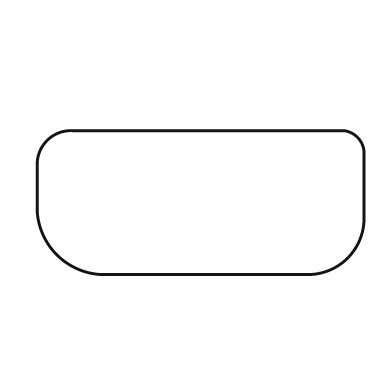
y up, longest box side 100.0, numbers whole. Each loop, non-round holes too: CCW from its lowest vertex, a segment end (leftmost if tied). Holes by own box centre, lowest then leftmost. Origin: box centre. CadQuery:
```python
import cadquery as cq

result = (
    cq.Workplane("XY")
    .moveTo(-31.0, -22.0)
    .lineTo(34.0, -22.0)
    .threePointArc((45.0, -17.0), (50.0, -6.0))
    .lineTo(50.0, 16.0)
    .threePointArc((48.0, 20.0), (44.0, 22.0))
    .lineTo(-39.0, 22.0)
    .threePointArc((-47.0, 19.0), (-50.0, 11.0))
    .lineTo(-50.0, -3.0)
    .threePointArc((-44.0, -16.0), (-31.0, -22.0))
    .close()
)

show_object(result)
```